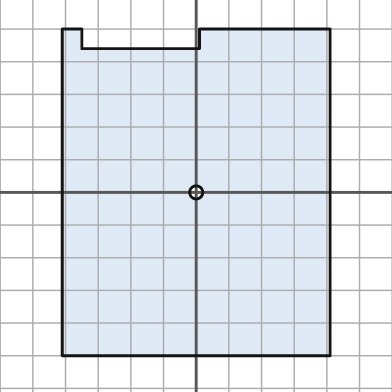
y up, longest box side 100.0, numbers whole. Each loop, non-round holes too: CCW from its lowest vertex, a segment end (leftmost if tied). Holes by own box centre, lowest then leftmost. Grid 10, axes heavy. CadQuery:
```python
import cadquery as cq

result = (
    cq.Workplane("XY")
    .moveTo(-41.0, -50.0)
    .lineTo(41.0, -50.0)
    .lineTo(41.0, 50.0)
    .lineTo(1.0, 50.0)
    .lineTo(1.0, 44.0)
    .lineTo(-35.0, 44.0)
    .lineTo(-35.0, 50.0)
    .lineTo(-41.0, 50.0)
    .close()
    .moveTo(0.0, 0.0)
    .circle(2.0)
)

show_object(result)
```